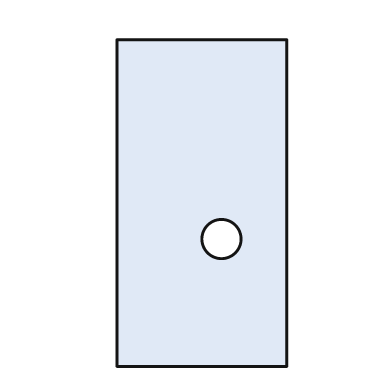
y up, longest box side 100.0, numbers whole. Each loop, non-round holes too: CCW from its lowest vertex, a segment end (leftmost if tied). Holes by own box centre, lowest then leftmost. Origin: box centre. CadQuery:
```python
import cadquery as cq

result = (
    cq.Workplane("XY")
    .moveTo(-26.0, -50.0)
    .lineTo(26.0, -50.0)
    .lineTo(26.0, 50.0)
    .lineTo(-26.0, 50.0)
    .close()
    .moveTo(6.0, -11.0)
    .circle(6.0)
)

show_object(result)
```